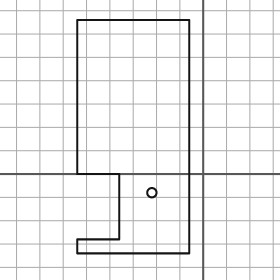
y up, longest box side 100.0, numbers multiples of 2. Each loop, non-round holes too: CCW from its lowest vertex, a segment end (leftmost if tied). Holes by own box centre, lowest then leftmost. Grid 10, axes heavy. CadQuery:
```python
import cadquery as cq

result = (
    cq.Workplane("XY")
    .moveTo(-54.0, -34.0)
    .lineTo(-6.0, -34.0)
    .lineTo(-6.0, 66.0)
    .lineTo(-54.0, 66.0)
    .lineTo(-54.0, 0.0)
    .lineTo(-36.0, 0.0)
    .lineTo(-36.0, -28.0)
    .lineTo(-54.0, -28.0)
    .close()
    .moveTo(-22.0, -8.0)
    .circle(2.0)
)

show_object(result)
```